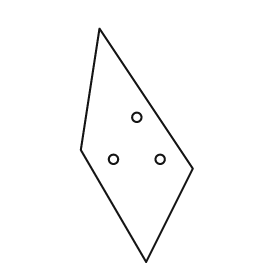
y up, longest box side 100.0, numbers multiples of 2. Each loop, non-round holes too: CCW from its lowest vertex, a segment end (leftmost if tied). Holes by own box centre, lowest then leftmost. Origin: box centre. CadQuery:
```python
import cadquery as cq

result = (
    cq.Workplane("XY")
    .moveTo(4.0, -50.0)
    .lineTo(24.0, -10.0)
    .lineTo(-16.0, 50.0)
    .lineTo(-24.0, -2.0)
    .close()
    .moveTo(-10.0, -6.0)
    .circle(2.0)
    .moveTo(10.0, -6.0)
    .circle(2.0)
    .moveTo(0.0, 12.0)
    .circle(2.0)
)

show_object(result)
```